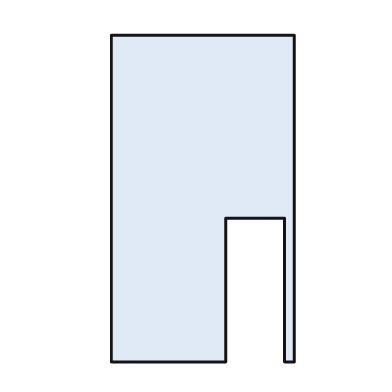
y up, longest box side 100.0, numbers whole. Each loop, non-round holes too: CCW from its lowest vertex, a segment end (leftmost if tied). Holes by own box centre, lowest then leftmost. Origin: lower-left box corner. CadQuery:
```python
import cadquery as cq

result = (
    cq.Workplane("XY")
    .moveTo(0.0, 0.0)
    .lineTo(35.0, 0.0)
    .lineTo(35.0, 44.0)
    .lineTo(53.0, 44.0)
    .lineTo(53.0, 0.0)
    .lineTo(56.0, 0.0)
    .lineTo(56.0, 100.0)
    .lineTo(0.0, 100.0)
    .close()
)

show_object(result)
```